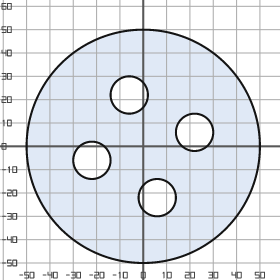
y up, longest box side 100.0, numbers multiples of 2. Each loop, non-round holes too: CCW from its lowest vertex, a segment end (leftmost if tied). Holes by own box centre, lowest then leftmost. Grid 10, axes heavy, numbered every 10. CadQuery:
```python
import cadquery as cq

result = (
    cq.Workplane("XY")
    .moveTo(0.0, 0.0)
    .circle(50.0)
    .moveTo(6.0, -22.0)
    .circle(8.0)
    .moveTo(-22.0, -6.0)
    .circle(8.0)
    .moveTo(22.0, 6.0)
    .circle(8.0)
    .moveTo(-6.0, 22.0)
    .circle(8.0)
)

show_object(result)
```